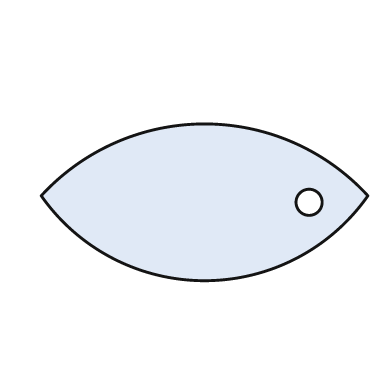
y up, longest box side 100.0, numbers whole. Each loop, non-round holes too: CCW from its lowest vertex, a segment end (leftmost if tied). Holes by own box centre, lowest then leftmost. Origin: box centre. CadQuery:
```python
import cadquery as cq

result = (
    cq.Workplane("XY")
    .moveTo(-50.0, 2.0)
    .threePointArc((0.0, -24.0), (50.0, 2.0))
    .threePointArc((0.0, 24.0), (-50.0, 2.0))
    .close()
    .moveTo(32.0, 0.0)
    .circle(4.0)
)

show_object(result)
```